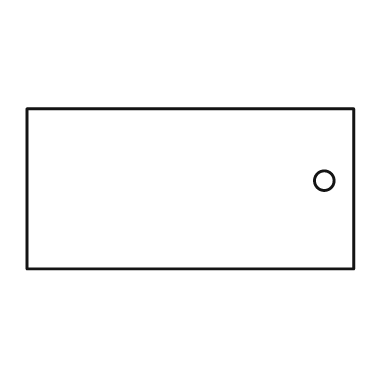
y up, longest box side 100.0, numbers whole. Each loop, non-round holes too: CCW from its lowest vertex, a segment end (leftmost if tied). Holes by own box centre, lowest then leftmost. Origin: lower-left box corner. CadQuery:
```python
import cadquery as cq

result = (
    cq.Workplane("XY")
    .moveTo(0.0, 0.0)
    .lineTo(100.0, 0.0)
    .lineTo(100.0, 49.0)
    .lineTo(0.0, 49.0)
    .close()
    .moveTo(91.0, 27.0)
    .circle(3.0)
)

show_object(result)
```